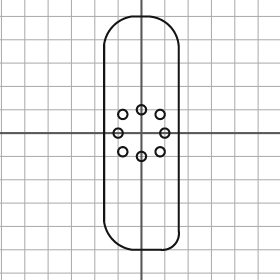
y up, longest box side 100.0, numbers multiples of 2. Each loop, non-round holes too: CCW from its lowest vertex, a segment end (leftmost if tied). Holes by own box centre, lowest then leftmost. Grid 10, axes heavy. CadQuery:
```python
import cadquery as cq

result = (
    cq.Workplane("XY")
    .moveTo(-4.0, -50.0)
    .lineTo(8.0, -50.0)
    .threePointArc((14.0, -48.0), (16.0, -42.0))
    .lineTo(16.0, 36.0)
    .threePointArc((12.0, 46.0), (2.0, 50.0))
    .lineTo(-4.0, 50.0)
    .threePointArc((-12.0, 46.0), (-16.0, 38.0))
    .lineTo(-16.0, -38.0)
    .threePointArc((-12.0, -46.0), (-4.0, -50.0))
    .close()
    .moveTo(0.0, -10.0)
    .circle(2.0)
    .moveTo(-8.0, -8.0)
    .circle(2.0)
    .moveTo(8.0, -8.0)
    .circle(2.0)
    .moveTo(-10.0, 0.0)
    .circle(2.0)
    .moveTo(10.0, 0.0)
    .circle(2.0)
    .moveTo(-8.0, 8.0)
    .circle(2.0)
    .moveTo(8.0, 8.0)
    .circle(2.0)
    .moveTo(0.0, 10.0)
    .circle(2.0)
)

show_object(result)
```